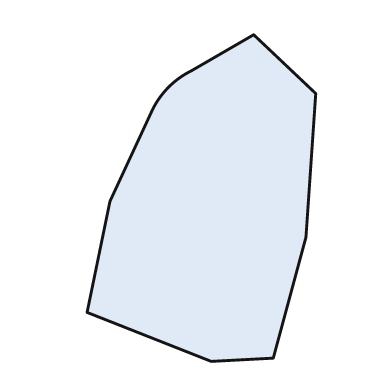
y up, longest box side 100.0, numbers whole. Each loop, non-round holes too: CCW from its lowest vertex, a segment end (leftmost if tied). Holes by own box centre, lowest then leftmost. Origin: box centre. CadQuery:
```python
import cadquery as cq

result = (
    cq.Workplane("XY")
    .moveTo(3.0, -50.0)
    .lineTo(22.0, -49.0)
    .lineTo(32.0, -12.0)
    .lineTo(35.0, 32.0)
    .lineTo(16.0, 50.0)
    .lineTo(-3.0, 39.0)
    .threePointArc((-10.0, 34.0), (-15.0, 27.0))
    .lineTo(-28.0, -1.0)
    .lineTo(-35.0, -35.0)
    .close()
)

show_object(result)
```